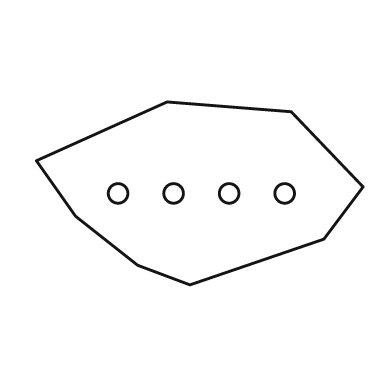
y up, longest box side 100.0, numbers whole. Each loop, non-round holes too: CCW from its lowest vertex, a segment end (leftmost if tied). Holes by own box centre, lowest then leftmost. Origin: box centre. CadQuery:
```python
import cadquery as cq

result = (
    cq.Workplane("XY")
    .moveTo(-3.0, -28.0)
    .lineTo(38.0, -14.0)
    .lineTo(50.0, 2.0)
    .lineTo(28.0, 25.0)
    .lineTo(-10.0, 28.0)
    .lineTo(-50.0, 10.0)
    .lineTo(-38.0, -7.0)
    .lineTo(-19.0, -22.0)
    .close()
    .moveTo(-25.0, 0.0)
    .circle(3.0)
    .moveTo(-8.0, 0.0)
    .circle(3.0)
    .moveTo(9.0, 0.0)
    .circle(3.0)
    .moveTo(26.0, 0.0)
    .circle(3.0)
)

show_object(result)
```